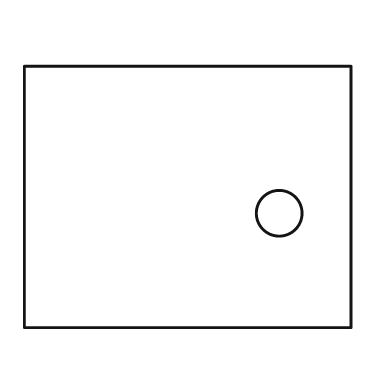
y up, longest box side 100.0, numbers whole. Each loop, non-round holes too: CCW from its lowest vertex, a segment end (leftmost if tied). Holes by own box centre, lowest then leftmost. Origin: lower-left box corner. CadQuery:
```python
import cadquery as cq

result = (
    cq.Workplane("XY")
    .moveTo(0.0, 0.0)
    .lineTo(100.0, 0.0)
    .lineTo(100.0, 80.0)
    .lineTo(0.0, 80.0)
    .close()
    .moveTo(78.0, 35.0)
    .circle(7.0)
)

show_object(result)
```